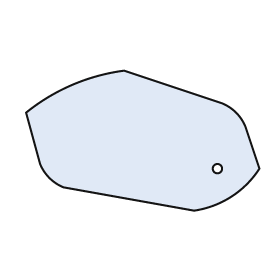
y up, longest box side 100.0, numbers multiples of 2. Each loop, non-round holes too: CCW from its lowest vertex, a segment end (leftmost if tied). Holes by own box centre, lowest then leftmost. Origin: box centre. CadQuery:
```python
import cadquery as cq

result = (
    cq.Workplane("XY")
    .moveTo(22.0, -30.0)
    .threePointArc((38.0, -24.0), (50.0, -12.0))
    .lineTo(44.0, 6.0)
    .threePointArc((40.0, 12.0), (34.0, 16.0))
    .lineTo(-8.0, 30.0)
    .threePointArc((-30.0, 24.0), (-50.0, 12.0))
    .lineTo(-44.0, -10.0)
    .threePointArc((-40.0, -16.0), (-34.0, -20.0))
    .close()
    .moveTo(32.0, -12.0)
    .circle(2.0)
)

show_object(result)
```